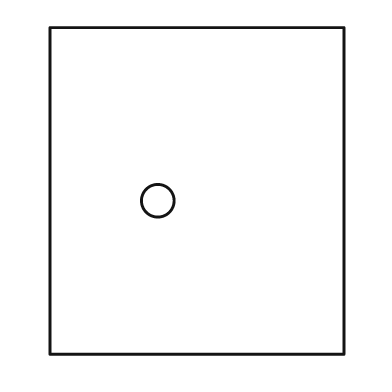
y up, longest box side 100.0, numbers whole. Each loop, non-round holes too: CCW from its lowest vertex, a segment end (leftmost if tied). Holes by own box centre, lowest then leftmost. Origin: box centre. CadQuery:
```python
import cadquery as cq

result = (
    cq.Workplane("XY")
    .moveTo(-45.0, -50.0)
    .lineTo(45.0, -50.0)
    .lineTo(45.0, 50.0)
    .lineTo(-45.0, 50.0)
    .close()
    .moveTo(-12.0, -3.0)
    .circle(5.0)
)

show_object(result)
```